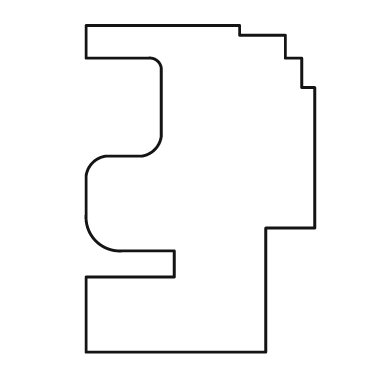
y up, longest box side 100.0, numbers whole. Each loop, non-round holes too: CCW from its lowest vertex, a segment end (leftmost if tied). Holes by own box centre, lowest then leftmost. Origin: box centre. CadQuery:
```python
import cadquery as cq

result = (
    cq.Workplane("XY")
    .moveTo(-35.0, -50.0)
    .lineTo(20.0, -50.0)
    .lineTo(20.0, -12.0)
    .lineTo(35.0, -12.0)
    .lineTo(35.0, 31.0)
    .lineTo(31.0, 31.0)
    .lineTo(31.0, 40.0)
    .lineTo(26.0, 40.0)
    .lineTo(26.0, 47.0)
    .lineTo(12.0, 47.0)
    .lineTo(12.0, 50.0)
    .lineTo(-35.0, 50.0)
    .lineTo(-35.0, 40.0)
    .lineTo(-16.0, 40.0)
    .threePointArc((-13.0, 39.0), (-12.0, 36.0))
    .lineTo(-12.0, 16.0)
    .threePointArc((-14.0, 12.0), (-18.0, 10.0))
    .lineTo(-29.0, 10.0)
    .threePointArc((-33.0, 8.0), (-35.0, 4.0))
    .lineTo(-35.0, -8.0)
    .threePointArc((-32.0, -16.0), (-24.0, -19.0))
    .lineTo(-8.0, -19.0)
    .lineTo(-8.0, -27.0)
    .lineTo(-35.0, -27.0)
    .close()
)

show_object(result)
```